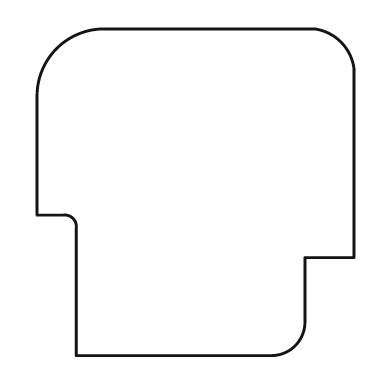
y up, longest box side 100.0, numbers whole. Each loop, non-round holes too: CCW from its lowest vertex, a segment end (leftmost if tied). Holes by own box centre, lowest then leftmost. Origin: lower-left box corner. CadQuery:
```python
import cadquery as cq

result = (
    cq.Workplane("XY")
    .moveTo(12.0, 0.0)
    .lineTo(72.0, 0.0)
    .threePointArc((79.0, 3.0), (82.0, 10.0))
    .lineTo(82.0, 30.0)
    .lineTo(97.0, 30.0)
    .lineTo(97.0, 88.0)
    .threePointArc((93.0, 96.0), (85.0, 100.0))
    .lineTo(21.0, 100.0)
    .threePointArc((6.0, 94.0), (0.0, 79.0))
    .lineTo(0.0, 43.0)
    .lineTo(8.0, 43.0)
    .threePointArc((11.0, 42.0), (12.0, 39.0))
    .close()
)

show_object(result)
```